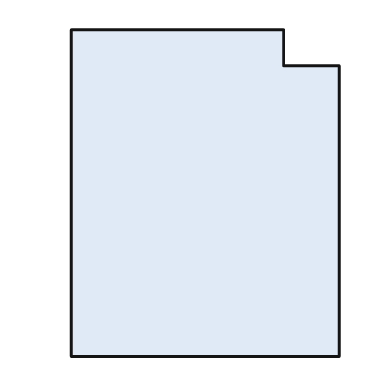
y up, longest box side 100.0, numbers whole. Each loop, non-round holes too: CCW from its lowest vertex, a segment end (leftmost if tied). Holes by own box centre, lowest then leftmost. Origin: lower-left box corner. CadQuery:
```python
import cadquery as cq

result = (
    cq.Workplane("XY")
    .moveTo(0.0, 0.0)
    .lineTo(82.0, 0.0)
    .lineTo(82.0, 89.0)
    .lineTo(65.0, 89.0)
    .lineTo(65.0, 100.0)
    .lineTo(0.0, 100.0)
    .close()
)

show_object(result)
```